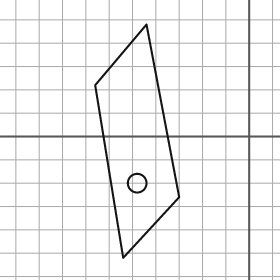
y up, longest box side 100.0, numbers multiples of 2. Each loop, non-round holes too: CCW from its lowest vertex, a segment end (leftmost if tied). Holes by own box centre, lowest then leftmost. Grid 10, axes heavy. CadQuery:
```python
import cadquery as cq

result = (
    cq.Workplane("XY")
    .moveTo(-54.0, -52.0)
    .lineTo(-30.0, -26.0)
    .lineTo(-44.0, 48.0)
    .lineTo(-66.0, 22.0)
    .close()
    .moveTo(-48.0, -20.0)
    .circle(4.0)
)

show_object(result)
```